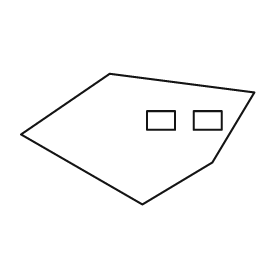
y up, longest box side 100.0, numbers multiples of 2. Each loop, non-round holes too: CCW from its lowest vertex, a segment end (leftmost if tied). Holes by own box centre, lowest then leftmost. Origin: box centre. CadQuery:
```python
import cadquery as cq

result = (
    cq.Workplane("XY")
    .moveTo(2.0, -28.0)
    .lineTo(32.0, -10.0)
    .lineTo(50.0, 20.0)
    .lineTo(-12.0, 28.0)
    .lineTo(-50.0, 2.0)
    .close()
    .moveTo(4.0, 4.0)
    .lineTo(16.0, 4.0)
    .lineTo(16.0, 12.0)
    .lineTo(4.0, 12.0)
    .close()
    .moveTo(24.0, 4.0)
    .lineTo(36.0, 4.0)
    .lineTo(36.0, 12.0)
    .lineTo(24.0, 12.0)
    .close()
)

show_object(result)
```